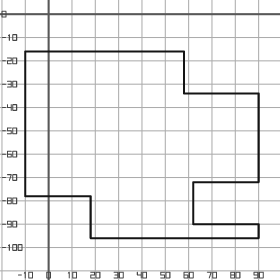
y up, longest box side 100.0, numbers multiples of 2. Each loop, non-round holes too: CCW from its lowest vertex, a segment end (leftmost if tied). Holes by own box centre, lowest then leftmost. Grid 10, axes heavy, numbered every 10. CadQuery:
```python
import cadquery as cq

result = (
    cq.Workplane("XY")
    .moveTo(18.0, -96.0)
    .lineTo(90.0, -96.0)
    .lineTo(90.0, -90.0)
    .lineTo(62.0, -90.0)
    .lineTo(62.0, -72.0)
    .lineTo(90.0, -72.0)
    .lineTo(90.0, -34.0)
    .lineTo(58.0, -34.0)
    .lineTo(58.0, -16.0)
    .lineTo(-10.0, -16.0)
    .lineTo(-10.0, -78.0)
    .lineTo(18.0, -78.0)
    .close()
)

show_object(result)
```